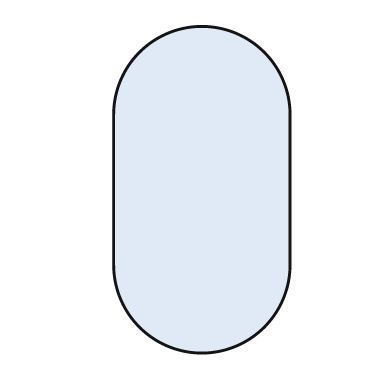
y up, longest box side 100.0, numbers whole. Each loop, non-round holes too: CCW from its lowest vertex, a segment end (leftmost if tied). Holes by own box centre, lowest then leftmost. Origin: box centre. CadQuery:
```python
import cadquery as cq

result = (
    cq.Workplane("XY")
    .moveTo(-27.0, -23.0)
    .threePointArc((0.0, -50.0), (27.0, -23.0))
    .lineTo(27.0, 23.0)
    .threePointArc((0.0, 50.0), (-27.0, 23.0))
    .close()
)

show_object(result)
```